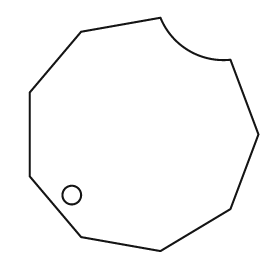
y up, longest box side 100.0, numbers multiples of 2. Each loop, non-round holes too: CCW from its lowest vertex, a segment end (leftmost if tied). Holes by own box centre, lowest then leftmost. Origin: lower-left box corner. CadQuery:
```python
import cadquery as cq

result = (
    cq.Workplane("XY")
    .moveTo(56.0, 0.0)
    .lineTo(86.0, 18.0)
    .lineTo(98.0, 50.0)
    .lineTo(86.0, 82.0)
    .threePointArc((68.0, 86.0), (56.0, 100.0))
    .lineTo(22.0, 94.0)
    .lineTo(0.0, 68.0)
    .lineTo(0.0, 32.0)
    .lineTo(22.0, 6.0)
    .close()
    .moveTo(18.0, 24.0)
    .circle(4.0)
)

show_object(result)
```